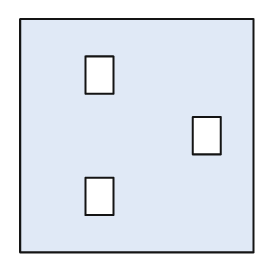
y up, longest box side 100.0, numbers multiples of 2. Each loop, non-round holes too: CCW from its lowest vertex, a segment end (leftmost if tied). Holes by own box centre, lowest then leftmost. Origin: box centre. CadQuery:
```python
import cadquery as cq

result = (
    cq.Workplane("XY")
    .moveTo(-50.0, -50.0)
    .lineTo(50.0, -50.0)
    .lineTo(50.0, 50.0)
    .lineTo(-50.0, 50.0)
    .close()
    .moveTo(-22.0, -34.0)
    .lineTo(-10.0, -34.0)
    .lineTo(-10.0, -18.0)
    .lineTo(-22.0, -18.0)
    .close()
    .moveTo(24.0, -8.0)
    .lineTo(36.0, -8.0)
    .lineTo(36.0, 8.0)
    .lineTo(24.0, 8.0)
    .close()
    .moveTo(-22.0, 18.0)
    .lineTo(-10.0, 18.0)
    .lineTo(-10.0, 34.0)
    .lineTo(-22.0, 34.0)
    .close()
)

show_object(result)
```